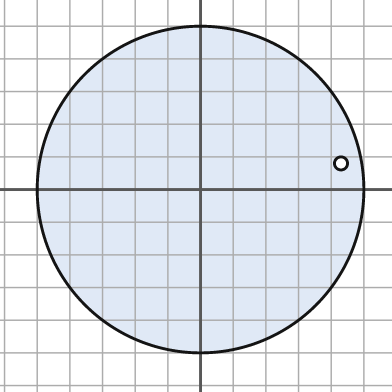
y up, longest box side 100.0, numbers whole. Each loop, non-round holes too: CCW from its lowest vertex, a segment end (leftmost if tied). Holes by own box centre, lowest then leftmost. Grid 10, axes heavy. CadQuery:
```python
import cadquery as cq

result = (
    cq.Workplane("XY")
    .moveTo(0.0, 0.0)
    .circle(50.0)
    .moveTo(43.0, 8.0)
    .circle(2.0)
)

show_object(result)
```